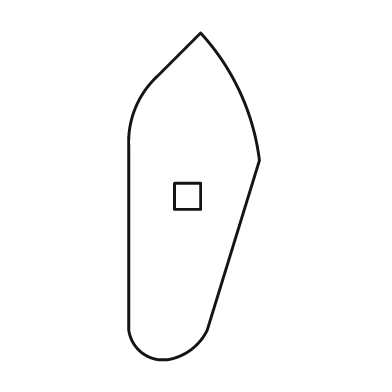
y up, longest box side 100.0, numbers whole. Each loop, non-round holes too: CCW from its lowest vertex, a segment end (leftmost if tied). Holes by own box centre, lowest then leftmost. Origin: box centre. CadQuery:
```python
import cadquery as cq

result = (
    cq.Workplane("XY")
    .moveTo(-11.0, -50.0)
    .lineTo(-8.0, -50.0)
    .threePointArc((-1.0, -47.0), (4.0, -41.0))
    .lineTo(20.0, 11.0)
    .threePointArc((14.0, 32.0), (2.0, 50.0))
    .lineTo(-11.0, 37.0)
    .threePointArc((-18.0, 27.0), (-20.0, 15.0))
    .lineTo(-20.0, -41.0)
    .threePointArc((-17.0, -47.0), (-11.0, -50.0))
    .close()
    .moveTo(-6.0, -4.0)
    .lineTo(2.0, -4.0)
    .lineTo(2.0, 4.0)
    .lineTo(-6.0, 4.0)
    .close()
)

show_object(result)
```